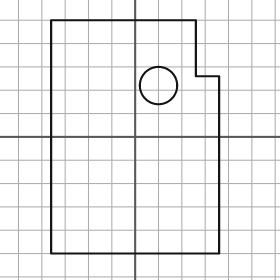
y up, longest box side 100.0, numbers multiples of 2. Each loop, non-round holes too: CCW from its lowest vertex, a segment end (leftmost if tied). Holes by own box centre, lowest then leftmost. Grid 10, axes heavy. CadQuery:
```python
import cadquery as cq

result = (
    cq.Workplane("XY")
    .moveTo(-36.0, -50.0)
    .lineTo(36.0, -50.0)
    .lineTo(36.0, 26.0)
    .lineTo(26.0, 26.0)
    .lineTo(26.0, 50.0)
    .lineTo(-36.0, 50.0)
    .close()
    .moveTo(10.0, 22.0)
    .circle(8.0)
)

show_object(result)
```